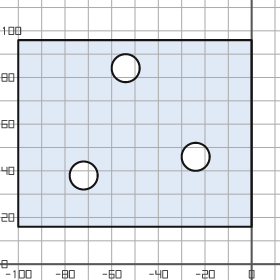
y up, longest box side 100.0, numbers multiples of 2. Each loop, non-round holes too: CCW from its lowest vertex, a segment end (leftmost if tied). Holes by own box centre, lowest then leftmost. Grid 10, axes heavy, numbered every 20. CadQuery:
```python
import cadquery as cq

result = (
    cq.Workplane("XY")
    .moveTo(-100.0, 16.0)
    .lineTo(0.0, 16.0)
    .lineTo(0.0, 96.0)
    .lineTo(-100.0, 96.0)
    .close()
    .moveTo(-72.0, 38.0)
    .circle(6.0)
    .moveTo(-24.0, 46.0)
    .circle(6.0)
    .moveTo(-54.0, 84.0)
    .circle(6.0)
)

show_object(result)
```